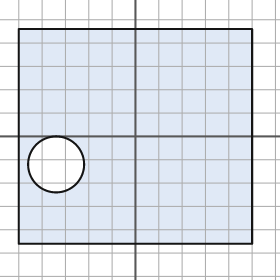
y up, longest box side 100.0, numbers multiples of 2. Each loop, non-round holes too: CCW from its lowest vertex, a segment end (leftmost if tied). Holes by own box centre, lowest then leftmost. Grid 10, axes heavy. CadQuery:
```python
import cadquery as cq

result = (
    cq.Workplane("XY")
    .moveTo(-50.0, -46.0)
    .lineTo(50.0, -46.0)
    .lineTo(50.0, 46.0)
    .lineTo(-50.0, 46.0)
    .close()
    .moveTo(-34.0, -12.0)
    .circle(12.0)
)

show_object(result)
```